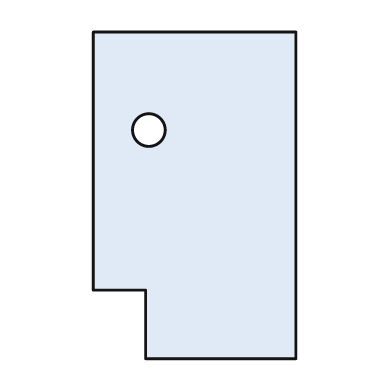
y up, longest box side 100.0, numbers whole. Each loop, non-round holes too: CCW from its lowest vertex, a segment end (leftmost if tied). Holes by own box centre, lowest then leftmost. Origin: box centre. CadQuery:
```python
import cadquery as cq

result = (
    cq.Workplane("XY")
    .moveTo(-15.0, -50.0)
    .lineTo(31.0, -50.0)
    .lineTo(31.0, 50.0)
    .lineTo(-31.0, 50.0)
    .lineTo(-31.0, -29.0)
    .lineTo(-15.0, -29.0)
    .close()
    .moveTo(-14.0, 20.0)
    .circle(5.0)
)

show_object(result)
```